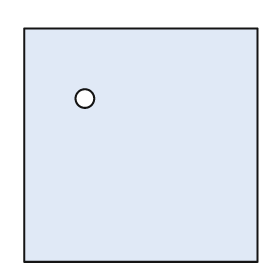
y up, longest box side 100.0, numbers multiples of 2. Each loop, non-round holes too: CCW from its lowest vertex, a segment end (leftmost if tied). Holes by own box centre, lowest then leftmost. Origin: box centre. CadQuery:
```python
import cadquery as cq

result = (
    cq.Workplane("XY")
    .moveTo(-50.0, -50.0)
    .lineTo(50.0, -50.0)
    .lineTo(50.0, 50.0)
    .lineTo(-50.0, 50.0)
    .close()
    .moveTo(-24.0, 20.0)
    .circle(4.0)
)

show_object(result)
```